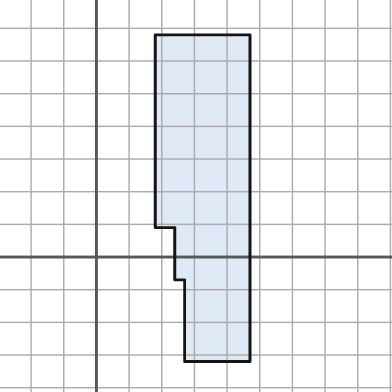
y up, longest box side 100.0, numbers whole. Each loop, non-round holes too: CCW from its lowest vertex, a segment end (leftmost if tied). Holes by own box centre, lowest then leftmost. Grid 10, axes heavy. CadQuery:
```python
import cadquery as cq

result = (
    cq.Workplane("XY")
    .moveTo(27.0, -32.0)
    .lineTo(47.0, -32.0)
    .lineTo(47.0, 68.0)
    .lineTo(18.0, 68.0)
    .lineTo(18.0, 9.0)
    .lineTo(24.0, 9.0)
    .lineTo(24.0, -7.0)
    .lineTo(27.0, -7.0)
    .close()
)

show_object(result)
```